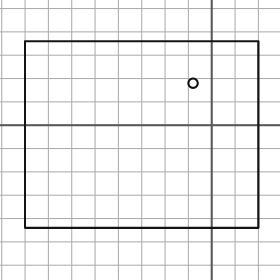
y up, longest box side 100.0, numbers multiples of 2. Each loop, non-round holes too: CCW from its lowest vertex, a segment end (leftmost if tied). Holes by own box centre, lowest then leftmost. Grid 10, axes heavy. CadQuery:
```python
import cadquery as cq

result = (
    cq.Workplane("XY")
    .moveTo(-80.0, -44.0)
    .lineTo(20.0, -44.0)
    .lineTo(20.0, 36.0)
    .lineTo(-80.0, 36.0)
    .close()
    .moveTo(-8.0, 18.0)
    .circle(2.0)
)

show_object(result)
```